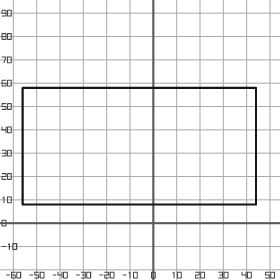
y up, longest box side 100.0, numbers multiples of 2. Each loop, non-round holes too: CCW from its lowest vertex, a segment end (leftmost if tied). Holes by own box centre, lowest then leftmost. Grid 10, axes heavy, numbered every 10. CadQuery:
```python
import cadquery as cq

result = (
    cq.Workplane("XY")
    .moveTo(-56.0, 8.0)
    .lineTo(44.0, 8.0)
    .lineTo(44.0, 58.0)
    .lineTo(-56.0, 58.0)
    .close()
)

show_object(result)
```